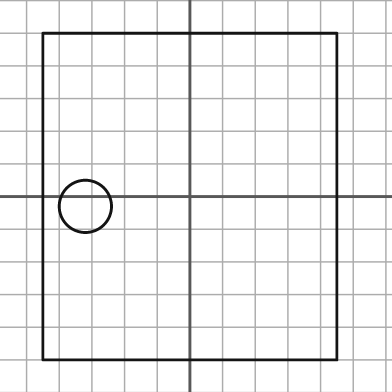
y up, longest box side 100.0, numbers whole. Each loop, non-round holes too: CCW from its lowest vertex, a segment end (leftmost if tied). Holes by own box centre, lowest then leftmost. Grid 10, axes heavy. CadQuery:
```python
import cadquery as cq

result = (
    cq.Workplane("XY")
    .moveTo(-45.0, -50.0)
    .lineTo(45.0, -50.0)
    .lineTo(45.0, 50.0)
    .lineTo(-45.0, 50.0)
    .close()
    .moveTo(-32.0, -3.0)
    .circle(8.0)
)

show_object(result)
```